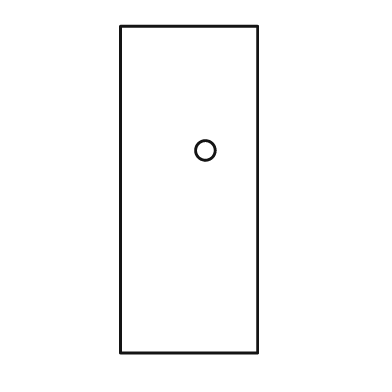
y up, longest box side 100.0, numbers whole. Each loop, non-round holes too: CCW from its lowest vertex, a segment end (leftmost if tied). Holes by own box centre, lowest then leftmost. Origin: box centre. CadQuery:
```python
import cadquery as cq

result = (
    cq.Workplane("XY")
    .moveTo(-21.0, -50.0)
    .lineTo(21.0, -50.0)
    .lineTo(21.0, 50.0)
    .lineTo(-21.0, 50.0)
    .close()
    .moveTo(5.0, 12.0)
    .circle(3.0)
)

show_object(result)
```